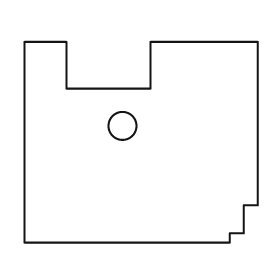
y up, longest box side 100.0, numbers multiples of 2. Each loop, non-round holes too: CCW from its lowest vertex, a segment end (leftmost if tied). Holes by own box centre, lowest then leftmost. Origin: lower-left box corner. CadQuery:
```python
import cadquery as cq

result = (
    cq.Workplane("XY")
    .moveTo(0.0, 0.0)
    .lineTo(88.0, 0.0)
    .lineTo(88.0, 4.0)
    .lineTo(94.0, 4.0)
    .lineTo(94.0, 16.0)
    .lineTo(100.0, 16.0)
    .lineTo(100.0, 86.0)
    .lineTo(54.0, 86.0)
    .lineTo(54.0, 66.0)
    .lineTo(18.0, 66.0)
    .lineTo(18.0, 86.0)
    .lineTo(0.0, 86.0)
    .close()
    .moveTo(42.0, 50.0)
    .circle(6.0)
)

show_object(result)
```